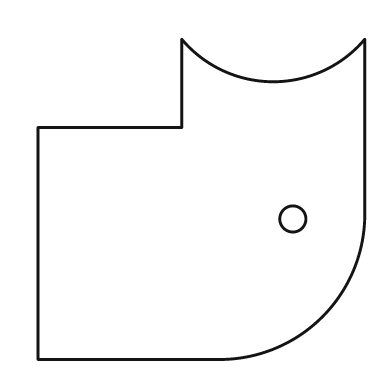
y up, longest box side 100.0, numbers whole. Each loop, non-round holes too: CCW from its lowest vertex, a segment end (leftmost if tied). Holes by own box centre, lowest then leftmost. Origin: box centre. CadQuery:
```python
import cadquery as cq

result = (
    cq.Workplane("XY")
    .moveTo(-50.0, -49.0)
    .lineTo(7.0, -49.0)
    .threePointArc((37.0, -36.0), (50.0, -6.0))
    .lineTo(50.0, 49.0)
    .threePointArc((22.0, 36.0), (-6.0, 49.0))
    .lineTo(-6.0, 22.0)
    .lineTo(-50.0, 22.0)
    .close()
    .moveTo(28.0, -6.0)
    .circle(4.0)
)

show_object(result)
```